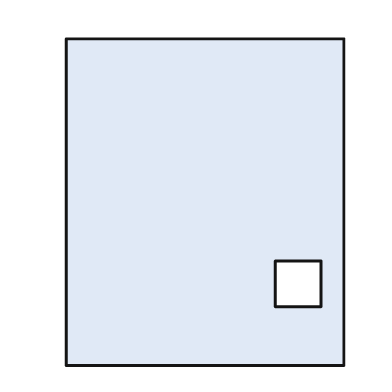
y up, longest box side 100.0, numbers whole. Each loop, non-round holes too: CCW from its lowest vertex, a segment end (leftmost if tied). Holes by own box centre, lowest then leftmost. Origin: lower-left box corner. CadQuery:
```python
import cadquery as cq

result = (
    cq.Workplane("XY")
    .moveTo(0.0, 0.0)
    .lineTo(85.0, 0.0)
    .lineTo(85.0, 100.0)
    .lineTo(0.0, 100.0)
    .close()
    .moveTo(64.0, 18.0)
    .lineTo(78.0, 18.0)
    .lineTo(78.0, 32.0)
    .lineTo(64.0, 32.0)
    .close()
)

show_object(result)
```